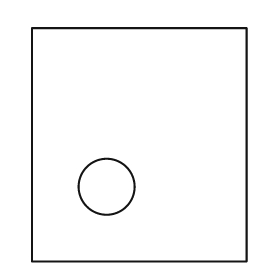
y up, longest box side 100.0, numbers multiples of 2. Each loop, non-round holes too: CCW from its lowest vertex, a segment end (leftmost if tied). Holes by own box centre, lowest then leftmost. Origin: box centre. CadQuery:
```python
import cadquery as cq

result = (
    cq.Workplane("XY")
    .moveTo(-46.0, -50.0)
    .lineTo(46.0, -50.0)
    .lineTo(46.0, 50.0)
    .lineTo(-46.0, 50.0)
    .close()
    .moveTo(-14.0, -18.0)
    .circle(12.0)
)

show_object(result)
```